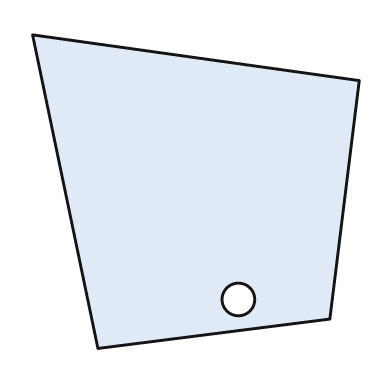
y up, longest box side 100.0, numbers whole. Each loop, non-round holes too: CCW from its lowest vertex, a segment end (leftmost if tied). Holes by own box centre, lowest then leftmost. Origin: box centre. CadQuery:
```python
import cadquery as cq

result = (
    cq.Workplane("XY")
    .moveTo(-30.0, -48.0)
    .lineTo(41.0, -39.0)
    .lineTo(50.0, 34.0)
    .lineTo(-50.0, 48.0)
    .close()
    .moveTo(13.0, -33.0)
    .circle(5.0)
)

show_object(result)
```